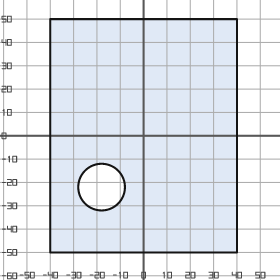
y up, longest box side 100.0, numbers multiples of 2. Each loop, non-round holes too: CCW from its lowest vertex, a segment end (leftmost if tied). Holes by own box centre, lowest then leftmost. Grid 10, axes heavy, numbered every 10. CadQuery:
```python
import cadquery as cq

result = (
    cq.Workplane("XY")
    .moveTo(-40.0, -50.0)
    .lineTo(40.0, -50.0)
    .lineTo(40.0, 50.0)
    .lineTo(-40.0, 50.0)
    .close()
    .moveTo(-18.0, -22.0)
    .circle(10.0)
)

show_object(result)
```